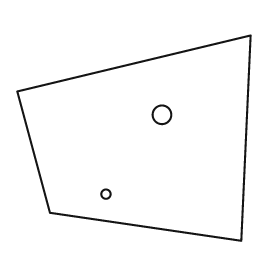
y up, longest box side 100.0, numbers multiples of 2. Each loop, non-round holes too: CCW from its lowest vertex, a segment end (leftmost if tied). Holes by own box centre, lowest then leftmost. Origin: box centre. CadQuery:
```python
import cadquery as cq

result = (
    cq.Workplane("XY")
    .moveTo(46.0, -44.0)
    .lineTo(50.0, 44.0)
    .lineTo(-50.0, 20.0)
    .lineTo(-36.0, -32.0)
    .close()
    .moveTo(-12.0, -24.0)
    .circle(2.0)
    .moveTo(12.0, 10.0)
    .circle(4.0)
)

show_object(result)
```